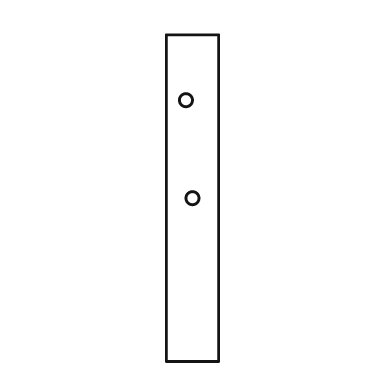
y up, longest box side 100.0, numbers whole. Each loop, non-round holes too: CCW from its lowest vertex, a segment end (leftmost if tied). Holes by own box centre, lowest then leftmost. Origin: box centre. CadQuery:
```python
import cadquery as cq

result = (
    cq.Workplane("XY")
    .moveTo(-8.0, -50.0)
    .lineTo(8.0, -50.0)
    .lineTo(8.0, 50.0)
    .lineTo(-8.0, 50.0)
    .close()
    .moveTo(0.0, 0.0)
    .circle(2.0)
    .moveTo(-2.0, 30.0)
    .circle(2.0)
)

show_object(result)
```